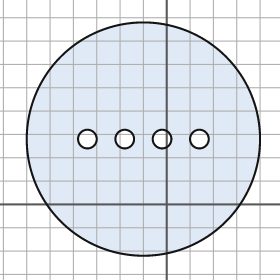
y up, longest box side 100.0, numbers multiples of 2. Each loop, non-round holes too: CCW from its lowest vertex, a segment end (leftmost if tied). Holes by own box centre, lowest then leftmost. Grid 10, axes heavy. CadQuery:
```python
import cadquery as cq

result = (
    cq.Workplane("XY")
    .moveTo(-10.0, 28.0)
    .circle(50.0)
    .moveTo(-34.0, 28.0)
    .circle(4.0)
    .moveTo(-18.0, 28.0)
    .circle(4.0)
    .moveTo(-2.0, 28.0)
    .circle(4.0)
    .moveTo(14.0, 28.0)
    .circle(4.0)
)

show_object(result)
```